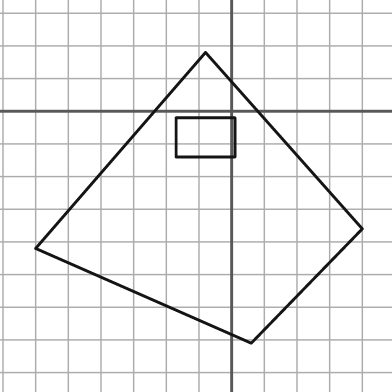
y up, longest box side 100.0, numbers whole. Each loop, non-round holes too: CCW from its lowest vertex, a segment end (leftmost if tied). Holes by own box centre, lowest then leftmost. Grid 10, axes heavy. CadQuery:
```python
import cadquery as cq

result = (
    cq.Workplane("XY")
    .moveTo(6.0, -71.0)
    .lineTo(40.0, -36.0)
    .lineTo(-8.0, 18.0)
    .lineTo(-60.0, -42.0)
    .close()
    .moveTo(-17.0, -14.0)
    .lineTo(1.0, -14.0)
    .lineTo(1.0, -2.0)
    .lineTo(-17.0, -2.0)
    .close()
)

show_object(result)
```